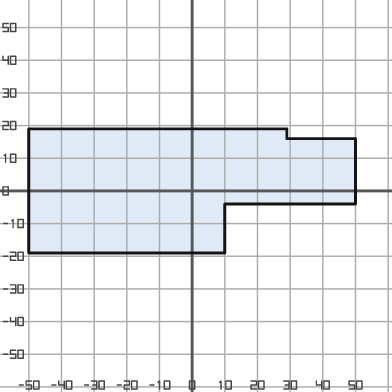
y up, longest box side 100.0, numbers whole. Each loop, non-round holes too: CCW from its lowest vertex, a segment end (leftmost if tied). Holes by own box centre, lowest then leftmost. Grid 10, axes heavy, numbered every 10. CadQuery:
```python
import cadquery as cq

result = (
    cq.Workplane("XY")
    .moveTo(-50.0, -19.0)
    .lineTo(10.0, -19.0)
    .lineTo(10.0, -4.0)
    .lineTo(50.0, -4.0)
    .lineTo(50.0, 16.0)
    .lineTo(29.0, 16.0)
    .lineTo(29.0, 19.0)
    .lineTo(-50.0, 19.0)
    .close()
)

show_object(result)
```